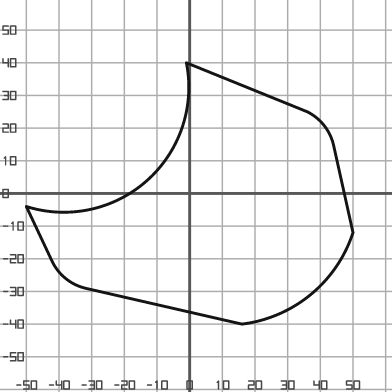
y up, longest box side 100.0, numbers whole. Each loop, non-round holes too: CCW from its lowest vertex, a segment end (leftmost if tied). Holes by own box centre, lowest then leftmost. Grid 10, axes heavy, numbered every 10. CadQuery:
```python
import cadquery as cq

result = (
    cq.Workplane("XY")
    .moveTo(16.0, -40.0)
    .threePointArc((37.0, -31.0), (50.0, -12.0))
    .lineTo(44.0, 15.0)
    .threePointArc((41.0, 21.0), (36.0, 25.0))
    .lineTo(-1.0, 40.0)
    .threePointArc((-13.0, 4.0), (-50.0, -4.0))
    .lineTo(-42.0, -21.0)
    .threePointArc((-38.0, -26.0), (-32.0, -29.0))
    .close()
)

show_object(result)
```